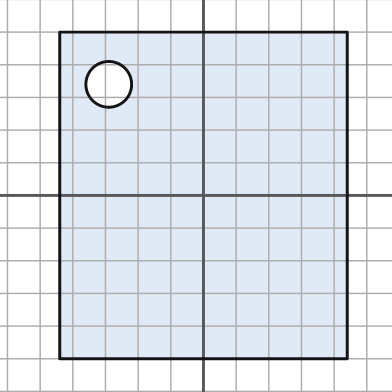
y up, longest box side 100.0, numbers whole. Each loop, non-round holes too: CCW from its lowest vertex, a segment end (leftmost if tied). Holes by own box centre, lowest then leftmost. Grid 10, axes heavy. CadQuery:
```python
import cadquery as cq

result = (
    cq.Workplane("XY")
    .moveTo(-44.0, -50.0)
    .lineTo(44.0, -50.0)
    .lineTo(44.0, 50.0)
    .lineTo(-44.0, 50.0)
    .close()
    .moveTo(-29.0, 34.0)
    .circle(7.0)
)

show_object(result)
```